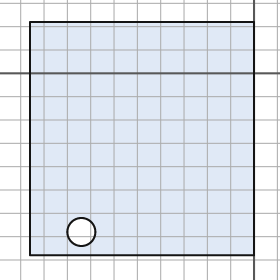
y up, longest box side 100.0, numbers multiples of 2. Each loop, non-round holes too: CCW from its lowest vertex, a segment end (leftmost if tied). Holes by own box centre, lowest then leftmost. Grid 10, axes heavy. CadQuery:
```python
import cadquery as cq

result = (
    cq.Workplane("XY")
    .moveTo(-96.0, -78.0)
    .lineTo(0.0, -78.0)
    .lineTo(0.0, 22.0)
    .lineTo(-96.0, 22.0)
    .close()
    .moveTo(-74.0, -68.0)
    .circle(6.0)
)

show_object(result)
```